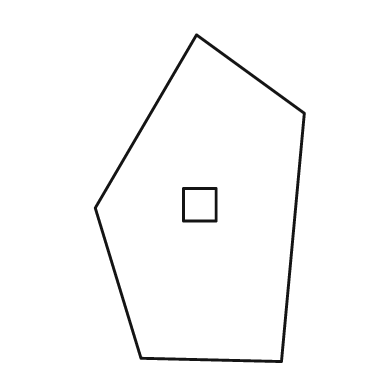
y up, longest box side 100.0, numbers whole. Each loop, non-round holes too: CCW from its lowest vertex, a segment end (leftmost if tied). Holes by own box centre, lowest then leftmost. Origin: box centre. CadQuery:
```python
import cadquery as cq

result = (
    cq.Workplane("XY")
    .moveTo(25.0, -50.0)
    .lineTo(32.0, 26.0)
    .lineTo(-1.0, 50.0)
    .lineTo(-32.0, -3.0)
    .lineTo(-18.0, -49.0)
    .close()
    .moveTo(-5.0, -7.0)
    .lineTo(5.0, -7.0)
    .lineTo(5.0, 3.0)
    .lineTo(-5.0, 3.0)
    .close()
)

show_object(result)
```